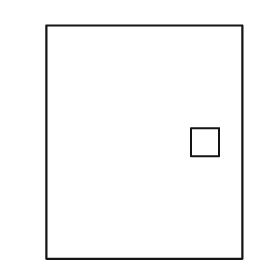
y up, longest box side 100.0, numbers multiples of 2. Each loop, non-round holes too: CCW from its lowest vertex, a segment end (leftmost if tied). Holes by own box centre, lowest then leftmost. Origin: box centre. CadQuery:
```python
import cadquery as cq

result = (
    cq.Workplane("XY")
    .moveTo(-42.0, -50.0)
    .lineTo(42.0, -50.0)
    .lineTo(42.0, 50.0)
    .lineTo(-42.0, 50.0)
    .close()
    .moveTo(20.0, -6.0)
    .lineTo(32.0, -6.0)
    .lineTo(32.0, 6.0)
    .lineTo(20.0, 6.0)
    .close()
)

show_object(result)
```